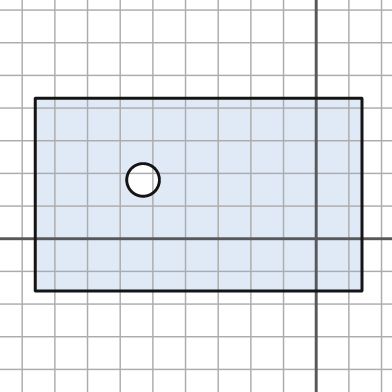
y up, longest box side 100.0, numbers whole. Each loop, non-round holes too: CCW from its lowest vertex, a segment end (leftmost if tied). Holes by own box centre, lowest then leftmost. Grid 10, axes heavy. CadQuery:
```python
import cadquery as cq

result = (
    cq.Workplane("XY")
    .moveTo(-86.0, -16.0)
    .lineTo(14.0, -16.0)
    .lineTo(14.0, 43.0)
    .lineTo(-86.0, 43.0)
    .close()
    .moveTo(-53.0, 18.0)
    .circle(5.0)
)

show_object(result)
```